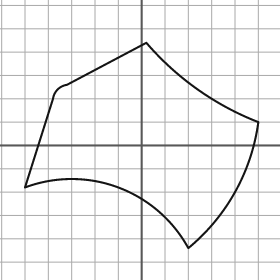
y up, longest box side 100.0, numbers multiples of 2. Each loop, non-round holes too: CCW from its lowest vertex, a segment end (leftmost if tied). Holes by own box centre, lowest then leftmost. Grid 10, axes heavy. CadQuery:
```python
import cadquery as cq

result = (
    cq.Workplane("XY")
    .moveTo(20.0, -44.0)
    .threePointArc((40.0, -20.0), (50.0, 10.0))
    .threePointArc((24.0, 24.0), (2.0, 44.0))
    .lineTo(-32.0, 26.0)
    .threePointArc((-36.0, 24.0), (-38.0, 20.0))
    .lineTo(-50.0, -18.0)
    .threePointArc((-10.0, -18.0), (20.0, -44.0))
    .close()
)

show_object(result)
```